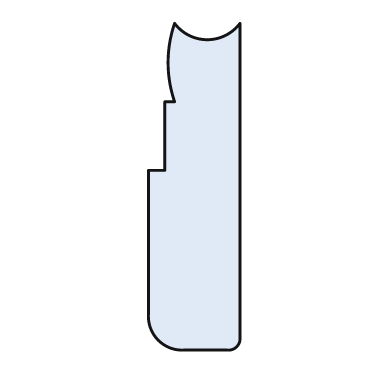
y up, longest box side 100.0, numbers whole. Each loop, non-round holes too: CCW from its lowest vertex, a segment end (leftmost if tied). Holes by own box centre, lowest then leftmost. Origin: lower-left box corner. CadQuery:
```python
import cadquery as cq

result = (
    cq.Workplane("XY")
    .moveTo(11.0, 0.0)
    .lineTo(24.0, 0.0)
    .threePointArc((27.0, 1.0), (28.0, 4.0))
    .lineTo(28.0, 100.0)
    .threePointArc((18.0, 95.0), (8.0, 100.0))
    .threePointArc((6.0, 88.0), (8.0, 76.0))
    .lineTo(5.0, 76.0)
    .lineTo(5.0, 55.0)
    .lineTo(0.0, 55.0)
    .lineTo(0.0, 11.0)
    .threePointArc((3.0, 3.0), (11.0, 0.0))
    .close()
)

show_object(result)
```